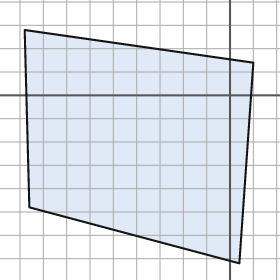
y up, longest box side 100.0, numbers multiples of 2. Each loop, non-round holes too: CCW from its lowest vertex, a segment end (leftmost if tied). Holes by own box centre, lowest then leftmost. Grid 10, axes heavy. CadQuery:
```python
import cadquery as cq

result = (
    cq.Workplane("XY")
    .moveTo(4.0, -72.0)
    .lineTo(10.0, 14.0)
    .lineTo(-88.0, 28.0)
    .lineTo(-86.0, -48.0)
    .close()
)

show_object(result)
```